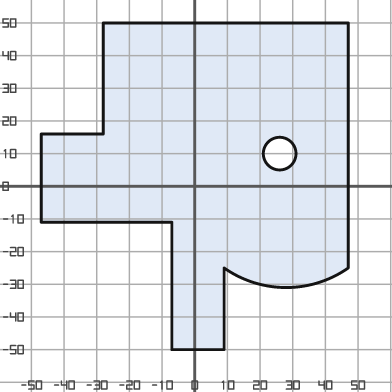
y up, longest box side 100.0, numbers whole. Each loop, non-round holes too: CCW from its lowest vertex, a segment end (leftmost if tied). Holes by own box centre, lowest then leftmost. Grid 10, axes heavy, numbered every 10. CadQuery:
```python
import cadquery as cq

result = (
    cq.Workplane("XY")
    .moveTo(-7.0, -50.0)
    .lineTo(9.0, -50.0)
    .lineTo(9.0, -25.0)
    .threePointArc((28.0, -31.0), (47.0, -25.0))
    .lineTo(47.0, 50.0)
    .lineTo(-28.0, 50.0)
    .lineTo(-28.0, 16.0)
    .lineTo(-47.0, 16.0)
    .lineTo(-47.0, -11.0)
    .lineTo(-7.0, -11.0)
    .close()
    .moveTo(26.0, 10.0)
    .circle(5.0)
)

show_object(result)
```